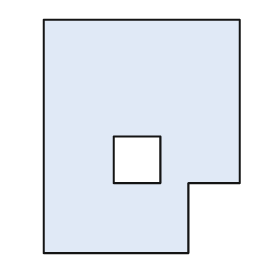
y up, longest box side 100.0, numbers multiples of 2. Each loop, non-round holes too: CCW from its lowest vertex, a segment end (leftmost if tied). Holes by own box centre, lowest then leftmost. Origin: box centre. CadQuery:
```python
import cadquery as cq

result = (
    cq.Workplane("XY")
    .moveTo(-42.0, -50.0)
    .lineTo(20.0, -50.0)
    .lineTo(20.0, -20.0)
    .lineTo(42.0, -20.0)
    .lineTo(42.0, 50.0)
    .lineTo(-42.0, 50.0)
    .close()
    .moveTo(-12.0, -20.0)
    .lineTo(8.0, -20.0)
    .lineTo(8.0, 0.0)
    .lineTo(-12.0, 0.0)
    .close()
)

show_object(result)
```